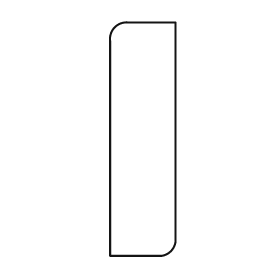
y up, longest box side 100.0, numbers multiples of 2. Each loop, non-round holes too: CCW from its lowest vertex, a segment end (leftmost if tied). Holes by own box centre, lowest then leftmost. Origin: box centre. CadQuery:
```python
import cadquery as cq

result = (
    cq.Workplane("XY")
    .moveTo(-14.0, -50.0)
    .lineTo(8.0, -50.0)
    .threePointArc((12.0, -48.0), (14.0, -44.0))
    .lineTo(14.0, 50.0)
    .lineTo(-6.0, 50.0)
    .threePointArc((-12.0, 48.0), (-14.0, 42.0))
    .close()
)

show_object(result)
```